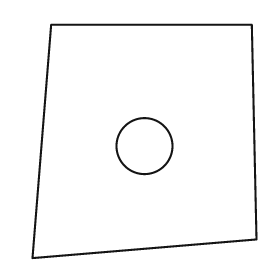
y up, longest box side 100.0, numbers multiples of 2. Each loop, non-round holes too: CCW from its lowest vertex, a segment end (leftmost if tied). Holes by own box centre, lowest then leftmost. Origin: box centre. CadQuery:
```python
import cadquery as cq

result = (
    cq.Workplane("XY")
    .moveTo(-48.0, -50.0)
    .lineTo(48.0, -42.0)
    .lineTo(46.0, 50.0)
    .lineTo(-40.0, 50.0)
    .close()
    .moveTo(0.0, -2.0)
    .circle(12.0)
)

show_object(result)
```